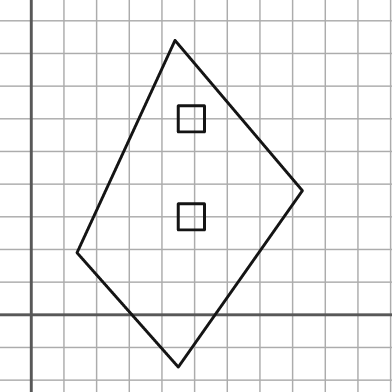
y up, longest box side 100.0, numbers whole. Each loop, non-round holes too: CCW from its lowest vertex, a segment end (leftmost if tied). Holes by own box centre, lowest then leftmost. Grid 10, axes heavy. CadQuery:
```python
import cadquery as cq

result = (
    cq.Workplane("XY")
    .moveTo(45.0, -16.0)
    .lineTo(83.0, 38.0)
    .lineTo(44.0, 84.0)
    .lineTo(14.0, 19.0)
    .close()
    .moveTo(45.0, 26.0)
    .lineTo(53.0, 26.0)
    .lineTo(53.0, 34.0)
    .lineTo(45.0, 34.0)
    .close()
    .moveTo(45.0, 56.0)
    .lineTo(53.0, 56.0)
    .lineTo(53.0, 64.0)
    .lineTo(45.0, 64.0)
    .close()
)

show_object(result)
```